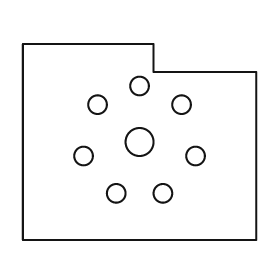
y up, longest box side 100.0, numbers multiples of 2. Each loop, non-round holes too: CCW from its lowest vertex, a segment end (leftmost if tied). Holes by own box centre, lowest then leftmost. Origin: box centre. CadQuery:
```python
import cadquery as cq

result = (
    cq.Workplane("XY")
    .moveTo(-50.0, -42.0)
    .lineTo(50.0, -42.0)
    .lineTo(50.0, 30.0)
    .lineTo(6.0, 30.0)
    .lineTo(6.0, 42.0)
    .lineTo(-50.0, 42.0)
    .close()
    .moveTo(-10.0, -22.0)
    .circle(4.0)
    .moveTo(10.0, -22.0)
    .circle(4.0)
    .moveTo(-24.0, -6.0)
    .circle(4.0)
    .moveTo(24.0, -6.0)
    .circle(4.0)
    .moveTo(0.0, 0.0)
    .circle(6.0)
    .moveTo(-18.0, 16.0)
    .circle(4.0)
    .moveTo(18.0, 16.0)
    .circle(4.0)
    .moveTo(0.0, 24.0)
    .circle(4.0)
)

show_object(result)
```